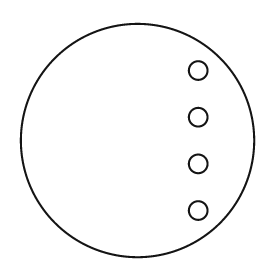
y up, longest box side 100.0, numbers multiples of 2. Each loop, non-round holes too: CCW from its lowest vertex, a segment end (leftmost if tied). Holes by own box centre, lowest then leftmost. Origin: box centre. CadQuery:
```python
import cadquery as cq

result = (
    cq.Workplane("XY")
    .moveTo(0.0, 0.0)
    .circle(50.0)
    .moveTo(26.0, -30.0)
    .circle(4.0)
    .moveTo(26.0, -10.0)
    .circle(4.0)
    .moveTo(26.0, 10.0)
    .circle(4.0)
    .moveTo(26.0, 30.0)
    .circle(4.0)
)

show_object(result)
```